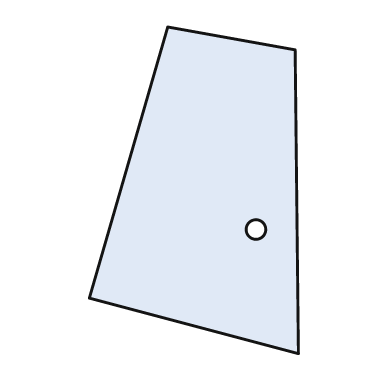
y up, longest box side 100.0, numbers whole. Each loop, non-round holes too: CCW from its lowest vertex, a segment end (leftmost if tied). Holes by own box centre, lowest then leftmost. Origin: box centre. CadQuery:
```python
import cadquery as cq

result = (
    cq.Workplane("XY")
    .moveTo(32.0, -50.0)
    .lineTo(31.0, 43.0)
    .lineTo(-8.0, 50.0)
    .lineTo(-32.0, -33.0)
    .close()
    .moveTo(19.0, -12.0)
    .circle(3.0)
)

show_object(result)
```